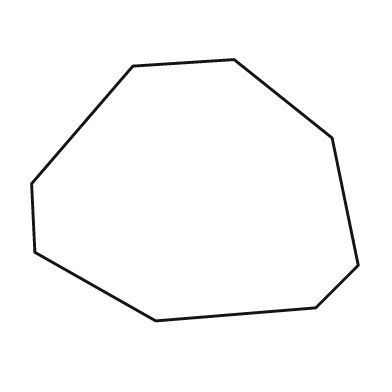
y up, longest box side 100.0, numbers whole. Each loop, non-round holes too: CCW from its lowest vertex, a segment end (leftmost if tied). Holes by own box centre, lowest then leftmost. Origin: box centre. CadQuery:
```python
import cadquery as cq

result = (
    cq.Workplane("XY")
    .moveTo(-12.0, -40.0)
    .lineTo(37.0, -36.0)
    .lineTo(50.0, -23.0)
    .lineTo(42.0, 16.0)
    .lineTo(12.0, 40.0)
    .lineTo(-19.0, 38.0)
    .lineTo(-50.0, 2.0)
    .lineTo(-49.0, -19.0)
    .close()
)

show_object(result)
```